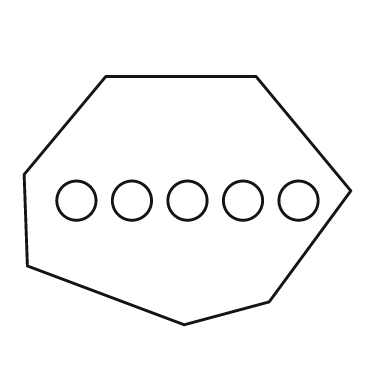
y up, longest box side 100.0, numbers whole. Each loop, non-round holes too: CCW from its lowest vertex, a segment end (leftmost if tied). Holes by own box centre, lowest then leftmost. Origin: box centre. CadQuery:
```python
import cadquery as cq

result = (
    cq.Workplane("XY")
    .moveTo(-1.0, -38.0)
    .lineTo(25.0, -31.0)
    .lineTo(50.0, 3.0)
    .lineTo(21.0, 38.0)
    .lineTo(-25.0, 38.0)
    .lineTo(-50.0, 8.0)
    .lineTo(-49.0, -20.0)
    .close()
    .moveTo(-34.0, 0.0)
    .circle(6.0)
    .moveTo(-17.0, 0.0)
    .circle(6.0)
    .moveTo(0.0, 0.0)
    .circle(6.0)
    .moveTo(17.0, 0.0)
    .circle(6.0)
    .moveTo(34.0, 0.0)
    .circle(6.0)
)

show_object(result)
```